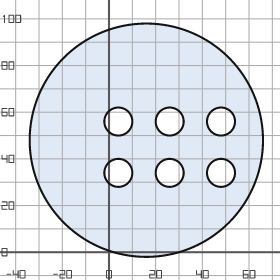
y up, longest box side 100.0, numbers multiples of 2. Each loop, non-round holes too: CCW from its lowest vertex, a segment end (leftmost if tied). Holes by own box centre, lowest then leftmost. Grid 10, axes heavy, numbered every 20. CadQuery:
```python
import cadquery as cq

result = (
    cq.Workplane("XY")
    .moveTo(16.0, 48.0)
    .circle(50.0)
    .moveTo(4.0, 34.0)
    .circle(6.0)
    .moveTo(26.0, 34.0)
    .circle(6.0)
    .moveTo(48.0, 34.0)
    .circle(6.0)
    .moveTo(4.0, 56.0)
    .circle(6.0)
    .moveTo(26.0, 56.0)
    .circle(6.0)
    .moveTo(48.0, 56.0)
    .circle(6.0)
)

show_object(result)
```